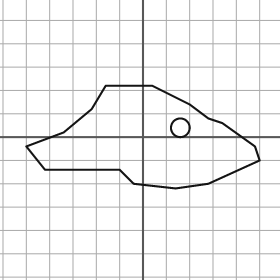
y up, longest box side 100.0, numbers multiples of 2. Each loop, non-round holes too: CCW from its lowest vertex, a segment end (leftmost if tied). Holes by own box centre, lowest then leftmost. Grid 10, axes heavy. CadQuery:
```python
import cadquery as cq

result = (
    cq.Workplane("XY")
    .moveTo(14.0, -22.0)
    .lineTo(28.0, -20.0)
    .lineTo(50.0, -10.0)
    .lineTo(48.0, -4.0)
    .lineTo(34.0, 6.0)
    .lineTo(28.0, 8.0)
    .lineTo(20.0, 14.0)
    .lineTo(4.0, 22.0)
    .lineTo(-16.0, 22.0)
    .lineTo(-22.0, 12.0)
    .lineTo(-34.0, 2.0)
    .lineTo(-50.0, -4.0)
    .lineTo(-42.0, -14.0)
    .lineTo(-10.0, -14.0)
    .lineTo(-4.0, -20.0)
    .close()
    .moveTo(16.0, 4.0)
    .circle(4.0)
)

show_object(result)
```